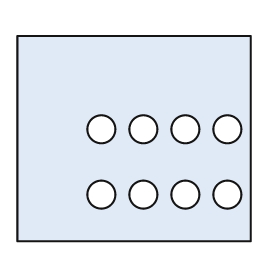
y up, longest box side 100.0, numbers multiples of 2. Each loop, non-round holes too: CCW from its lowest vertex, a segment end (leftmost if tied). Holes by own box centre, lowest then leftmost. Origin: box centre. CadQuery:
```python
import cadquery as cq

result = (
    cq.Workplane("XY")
    .moveTo(-50.0, -44.0)
    .lineTo(50.0, -44.0)
    .lineTo(50.0, 44.0)
    .lineTo(-50.0, 44.0)
    .close()
    .moveTo(-14.0, -24.0)
    .circle(6.0)
    .moveTo(4.0, -24.0)
    .circle(6.0)
    .moveTo(22.0, -24.0)
    .circle(6.0)
    .moveTo(40.0, -24.0)
    .circle(6.0)
    .moveTo(-14.0, 4.0)
    .circle(6.0)
    .moveTo(4.0, 4.0)
    .circle(6.0)
    .moveTo(22.0, 4.0)
    .circle(6.0)
    .moveTo(40.0, 4.0)
    .circle(6.0)
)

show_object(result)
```